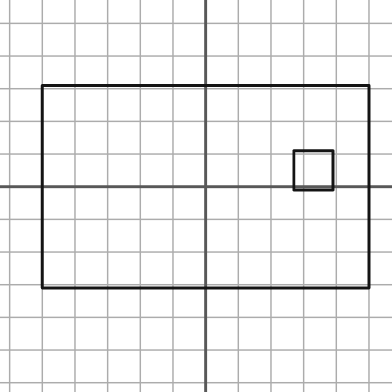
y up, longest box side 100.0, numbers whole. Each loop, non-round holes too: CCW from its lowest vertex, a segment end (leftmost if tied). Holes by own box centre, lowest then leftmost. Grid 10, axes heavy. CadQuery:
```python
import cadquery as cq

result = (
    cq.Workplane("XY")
    .moveTo(-50.0, -31.0)
    .lineTo(50.0, -31.0)
    .lineTo(50.0, 31.0)
    .lineTo(-50.0, 31.0)
    .close()
    .moveTo(27.0, -1.0)
    .lineTo(39.0, -1.0)
    .lineTo(39.0, 11.0)
    .lineTo(27.0, 11.0)
    .close()
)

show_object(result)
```